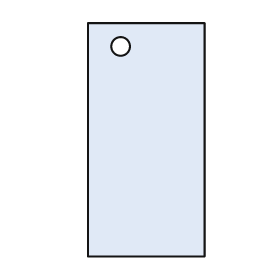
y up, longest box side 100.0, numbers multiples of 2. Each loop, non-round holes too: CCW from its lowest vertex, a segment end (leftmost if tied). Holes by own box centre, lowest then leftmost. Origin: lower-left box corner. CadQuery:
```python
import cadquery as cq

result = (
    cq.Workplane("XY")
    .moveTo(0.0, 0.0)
    .lineTo(50.0, 0.0)
    .lineTo(50.0, 100.0)
    .lineTo(0.0, 100.0)
    .close()
    .moveTo(14.0, 90.0)
    .circle(4.0)
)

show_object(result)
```